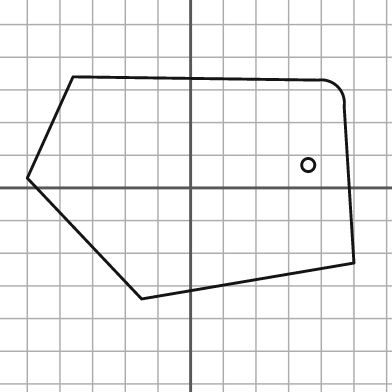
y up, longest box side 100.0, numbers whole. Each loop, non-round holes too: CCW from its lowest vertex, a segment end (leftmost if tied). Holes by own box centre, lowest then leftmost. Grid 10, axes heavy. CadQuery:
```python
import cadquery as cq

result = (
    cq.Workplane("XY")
    .moveTo(-15.0, -34.0)
    .lineTo(50.0, -23.0)
    .lineTo(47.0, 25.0)
    .threePointArc((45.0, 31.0), (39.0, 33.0))
    .lineTo(-36.0, 34.0)
    .lineTo(-50.0, 3.0)
    .close()
    .moveTo(36.0, 7.0)
    .circle(2.0)
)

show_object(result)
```